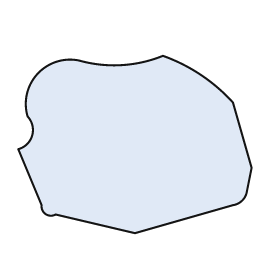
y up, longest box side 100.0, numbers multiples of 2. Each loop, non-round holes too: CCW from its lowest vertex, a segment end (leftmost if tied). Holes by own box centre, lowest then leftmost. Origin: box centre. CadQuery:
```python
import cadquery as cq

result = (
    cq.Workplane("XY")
    .moveTo(0.0, -38.0)
    .lineTo(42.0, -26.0)
    .threePointArc((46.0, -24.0), (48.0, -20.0))
    .lineTo(50.0, -10.0)
    .lineTo(42.0, 18.0)
    .threePointArc((28.0, 30.0), (12.0, 38.0))
    .threePointArc((-6.0, 34.0), (-24.0, 36.0))
    .threePointArc((-42.0, 30.0), (-46.0, 12.0))
    .threePointArc((-44.0, 4.0), (-50.0, -2.0))
    .lineTo(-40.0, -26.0)
    .threePointArc((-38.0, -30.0), (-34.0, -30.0))
    .close()
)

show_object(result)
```